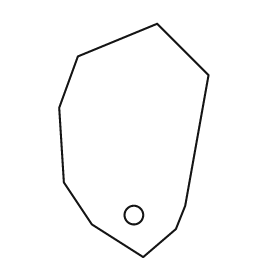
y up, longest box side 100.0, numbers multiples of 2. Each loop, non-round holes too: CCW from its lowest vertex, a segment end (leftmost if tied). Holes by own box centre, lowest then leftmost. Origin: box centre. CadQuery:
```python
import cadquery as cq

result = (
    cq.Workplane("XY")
    .moveTo(4.0, -50.0)
    .lineTo(18.0, -38.0)
    .lineTo(22.0, -28.0)
    .lineTo(32.0, 28.0)
    .lineTo(10.0, 50.0)
    .lineTo(-24.0, 36.0)
    .lineTo(-32.0, 14.0)
    .lineTo(-30.0, -18.0)
    .lineTo(-18.0, -36.0)
    .close()
    .moveTo(0.0, -32.0)
    .circle(4.0)
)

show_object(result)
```